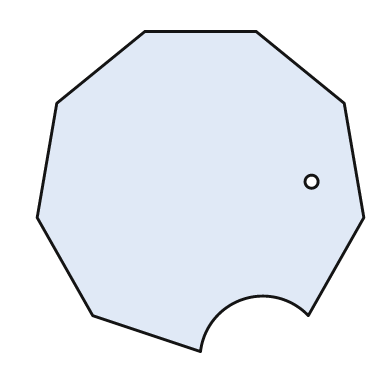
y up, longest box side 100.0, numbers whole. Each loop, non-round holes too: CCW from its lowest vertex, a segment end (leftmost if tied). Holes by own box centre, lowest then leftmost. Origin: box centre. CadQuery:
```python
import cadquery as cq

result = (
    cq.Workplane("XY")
    .moveTo(0.0, -49.0)
    .threePointArc((13.0, -33.0), (33.0, -38.0))
    .lineTo(50.0, -8.0)
    .lineTo(44.0, 27.0)
    .lineTo(17.0, 49.0)
    .lineTo(-17.0, 49.0)
    .lineTo(-44.0, 27.0)
    .lineTo(-50.0, -8.0)
    .lineTo(-33.0, -38.0)
    .close()
    .moveTo(34.0, 3.0)
    .circle(2.0)
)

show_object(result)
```